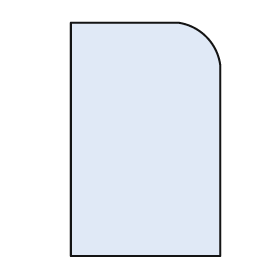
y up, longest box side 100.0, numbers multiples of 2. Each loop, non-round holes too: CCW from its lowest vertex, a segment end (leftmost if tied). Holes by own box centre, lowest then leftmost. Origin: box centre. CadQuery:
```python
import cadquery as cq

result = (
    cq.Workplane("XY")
    .moveTo(-32.0, -50.0)
    .lineTo(32.0, -50.0)
    .lineTo(32.0, 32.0)
    .threePointArc((26.0, 44.0), (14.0, 50.0))
    .lineTo(-32.0, 50.0)
    .close()
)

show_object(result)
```